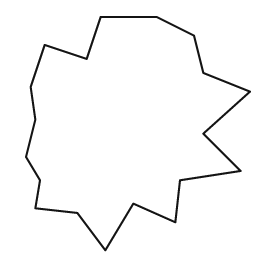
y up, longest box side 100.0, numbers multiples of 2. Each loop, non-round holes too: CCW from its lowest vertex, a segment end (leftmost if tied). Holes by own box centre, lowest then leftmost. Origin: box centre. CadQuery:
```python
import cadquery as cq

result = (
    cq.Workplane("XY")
    .moveTo(-14.0, -50.0)
    .lineTo(-2.0, -30.0)
    .lineTo(16.0, -38.0)
    .lineTo(18.0, -20.0)
    .lineTo(44.0, -16.0)
    .lineTo(28.0, 0.0)
    .lineTo(48.0, 18.0)
    .lineTo(28.0, 26.0)
    .lineTo(24.0, 42.0)
    .lineTo(8.0, 50.0)
    .lineTo(-16.0, 50.0)
    .lineTo(-22.0, 32.0)
    .lineTo(-40.0, 38.0)
    .lineTo(-46.0, 20.0)
    .lineTo(-44.0, 6.0)
    .lineTo(-48.0, -10.0)
    .lineTo(-42.0, -20.0)
    .lineTo(-44.0, -32.0)
    .lineTo(-26.0, -34.0)
    .close()
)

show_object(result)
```